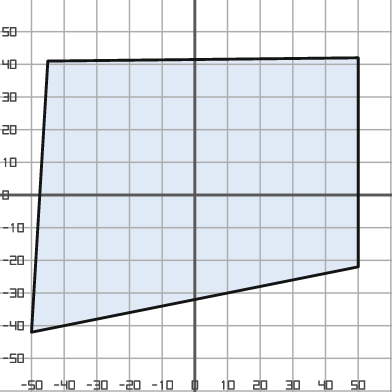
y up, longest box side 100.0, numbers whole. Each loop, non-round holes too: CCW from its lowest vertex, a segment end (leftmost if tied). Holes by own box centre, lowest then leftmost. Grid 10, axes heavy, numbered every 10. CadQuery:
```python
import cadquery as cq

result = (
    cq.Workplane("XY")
    .moveTo(-50.0, -42.0)
    .lineTo(50.0, -22.0)
    .lineTo(50.0, 42.0)
    .lineTo(-45.0, 41.0)
    .close()
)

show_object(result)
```